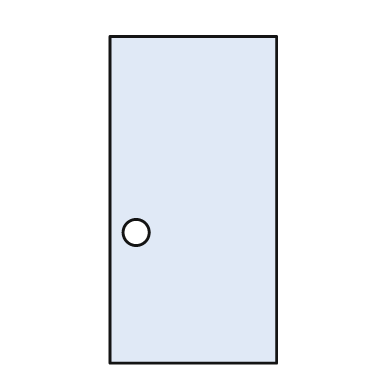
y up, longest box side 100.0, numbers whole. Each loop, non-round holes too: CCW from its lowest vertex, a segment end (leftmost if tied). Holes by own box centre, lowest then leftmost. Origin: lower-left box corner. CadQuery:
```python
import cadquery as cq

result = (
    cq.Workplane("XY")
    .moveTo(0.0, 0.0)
    .lineTo(51.0, 0.0)
    .lineTo(51.0, 100.0)
    .lineTo(0.0, 100.0)
    .close()
    .moveTo(8.0, 40.0)
    .circle(4.0)
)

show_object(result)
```